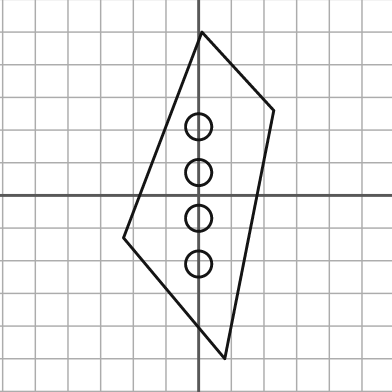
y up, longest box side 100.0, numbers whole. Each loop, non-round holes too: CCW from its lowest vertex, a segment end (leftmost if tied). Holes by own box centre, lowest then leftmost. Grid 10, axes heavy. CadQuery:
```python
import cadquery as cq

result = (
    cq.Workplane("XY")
    .moveTo(8.0, -50.0)
    .lineTo(23.0, 26.0)
    .lineTo(1.0, 50.0)
    .lineTo(-23.0, -13.0)
    .close()
    .moveTo(0.0, -21.0)
    .circle(4.0)
    .moveTo(0.0, -7.0)
    .circle(4.0)
    .moveTo(0.0, 7.0)
    .circle(4.0)
    .moveTo(0.0, 21.0)
    .circle(4.0)
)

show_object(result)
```